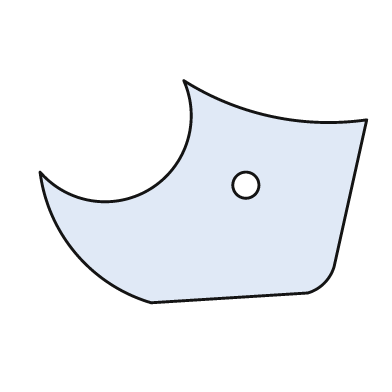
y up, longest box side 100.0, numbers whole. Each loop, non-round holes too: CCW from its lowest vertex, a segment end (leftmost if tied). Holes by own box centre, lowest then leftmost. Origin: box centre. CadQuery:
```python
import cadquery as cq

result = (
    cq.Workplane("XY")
    .moveTo(-16.0, -34.0)
    .lineTo(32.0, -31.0)
    .threePointArc((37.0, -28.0), (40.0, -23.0))
    .lineTo(50.0, 22.0)
    .threePointArc((21.0, 23.0), (-6.0, 34.0))
    .threePointArc((-16.0, 1.0), (-50.0, 6.0))
    .threePointArc((-39.0, -19.0), (-16.0, -34.0))
    .close()
    .moveTo(13.0, 2.0)
    .circle(4.0)
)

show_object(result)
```